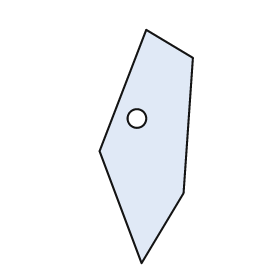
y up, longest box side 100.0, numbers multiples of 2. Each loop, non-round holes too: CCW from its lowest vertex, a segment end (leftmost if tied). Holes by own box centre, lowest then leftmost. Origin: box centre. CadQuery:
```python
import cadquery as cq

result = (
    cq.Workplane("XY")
    .moveTo(-2.0, -50.0)
    .lineTo(16.0, -20.0)
    .lineTo(20.0, 38.0)
    .lineTo(0.0, 50.0)
    .lineTo(-20.0, -2.0)
    .close()
    .moveTo(-4.0, 12.0)
    .circle(4.0)
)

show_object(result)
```